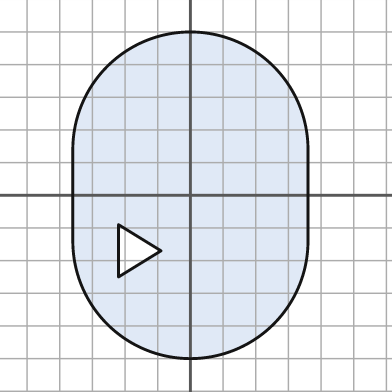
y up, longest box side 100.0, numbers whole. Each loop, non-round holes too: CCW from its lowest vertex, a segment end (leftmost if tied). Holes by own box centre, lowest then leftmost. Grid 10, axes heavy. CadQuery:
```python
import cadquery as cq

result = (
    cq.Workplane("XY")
    .moveTo(-36.0, -14.0)
    .threePointArc((0.0, -50.0), (36.0, -14.0))
    .lineTo(36.0, 14.0)
    .threePointArc((0.0, 50.0), (-36.0, 14.0))
    .close()
    .moveTo(-22.0, -25.0)
    .lineTo(-9.0, -17.0)
    .lineTo(-22.0, -9.0)
    .close()
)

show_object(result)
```